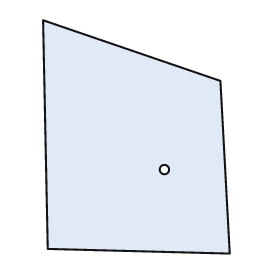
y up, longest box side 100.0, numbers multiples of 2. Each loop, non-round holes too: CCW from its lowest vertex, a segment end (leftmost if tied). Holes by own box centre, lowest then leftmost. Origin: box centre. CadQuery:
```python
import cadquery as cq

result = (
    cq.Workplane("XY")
    .moveTo(40.0, -50.0)
    .lineTo(36.0, 24.0)
    .lineTo(-40.0, 50.0)
    .lineTo(-38.0, -48.0)
    .close()
    .moveTo(12.0, -14.0)
    .circle(2.0)
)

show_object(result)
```